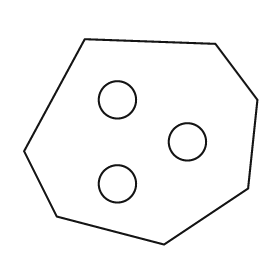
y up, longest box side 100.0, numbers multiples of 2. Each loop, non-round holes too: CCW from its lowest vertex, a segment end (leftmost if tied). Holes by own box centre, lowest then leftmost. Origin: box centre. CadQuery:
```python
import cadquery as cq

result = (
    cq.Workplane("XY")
    .moveTo(10.0, -44.0)
    .lineTo(46.0, -20.0)
    .lineTo(50.0, 18.0)
    .lineTo(32.0, 42.0)
    .lineTo(-24.0, 44.0)
    .lineTo(-50.0, -4.0)
    .lineTo(-36.0, -32.0)
    .close()
    .moveTo(-10.0, -18.0)
    .circle(8.0)
    .moveTo(20.0, 0.0)
    .circle(8.0)
    .moveTo(-10.0, 18.0)
    .circle(8.0)
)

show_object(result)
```